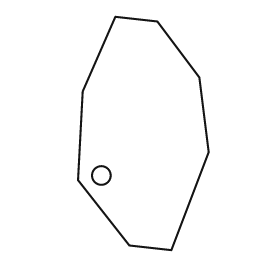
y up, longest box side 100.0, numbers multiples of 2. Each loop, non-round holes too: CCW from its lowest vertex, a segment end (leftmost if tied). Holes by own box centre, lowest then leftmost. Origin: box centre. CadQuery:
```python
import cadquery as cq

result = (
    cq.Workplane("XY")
    .moveTo(12.0, -50.0)
    .lineTo(28.0, -8.0)
    .lineTo(24.0, 24.0)
    .lineTo(6.0, 48.0)
    .lineTo(-12.0, 50.0)
    .lineTo(-26.0, 18.0)
    .lineTo(-28.0, -20.0)
    .lineTo(-6.0, -48.0)
    .close()
    .moveTo(-18.0, -18.0)
    .circle(4.0)
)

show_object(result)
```